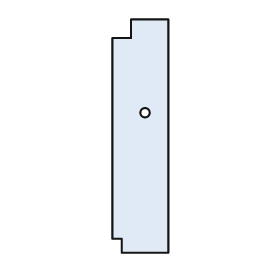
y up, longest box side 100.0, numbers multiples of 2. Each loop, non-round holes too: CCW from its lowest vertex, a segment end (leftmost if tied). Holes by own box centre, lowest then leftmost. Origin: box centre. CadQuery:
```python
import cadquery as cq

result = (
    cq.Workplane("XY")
    .moveTo(-8.0, -50.0)
    .lineTo(12.0, -50.0)
    .lineTo(12.0, 50.0)
    .lineTo(-4.0, 50.0)
    .lineTo(-4.0, 42.0)
    .lineTo(-12.0, 42.0)
    .lineTo(-12.0, -44.0)
    .lineTo(-8.0, -44.0)
    .close()
    .moveTo(2.0, 10.0)
    .circle(2.0)
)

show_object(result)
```